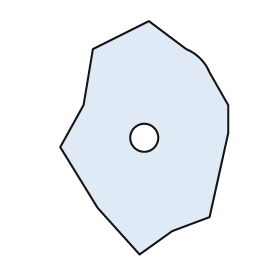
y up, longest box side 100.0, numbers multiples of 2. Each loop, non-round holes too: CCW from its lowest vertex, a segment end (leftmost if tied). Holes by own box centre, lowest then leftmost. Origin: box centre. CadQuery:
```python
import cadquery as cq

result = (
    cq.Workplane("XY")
    .moveTo(-2.0, -50.0)
    .lineTo(12.0, -40.0)
    .lineTo(28.0, -34.0)
    .lineTo(36.0, 2.0)
    .lineTo(36.0, 14.0)
    .lineTo(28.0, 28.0)
    .threePointArc((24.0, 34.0), (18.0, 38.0))
    .lineTo(2.0, 50.0)
    .lineTo(-22.0, 38.0)
    .lineTo(-26.0, 14.0)
    .lineTo(-36.0, -4.0)
    .lineTo(-20.0, -30.0)
    .close()
    .moveTo(0.0, 0.0)
    .circle(6.0)
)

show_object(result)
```